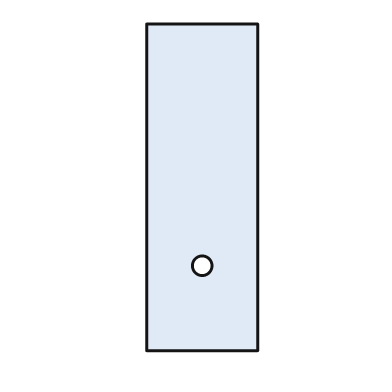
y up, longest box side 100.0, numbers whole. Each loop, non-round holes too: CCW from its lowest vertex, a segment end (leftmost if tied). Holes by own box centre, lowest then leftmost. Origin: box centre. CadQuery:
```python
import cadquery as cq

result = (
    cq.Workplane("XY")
    .moveTo(-17.0, -50.0)
    .lineTo(17.0, -50.0)
    .lineTo(17.0, 50.0)
    .lineTo(-17.0, 50.0)
    .close()
    .moveTo(0.0, -24.0)
    .circle(3.0)
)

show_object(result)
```